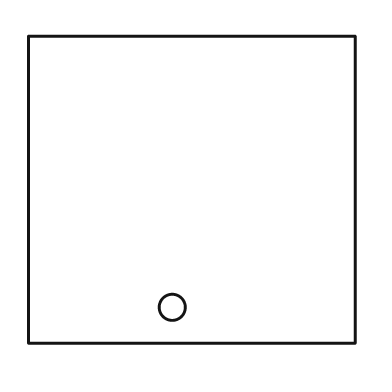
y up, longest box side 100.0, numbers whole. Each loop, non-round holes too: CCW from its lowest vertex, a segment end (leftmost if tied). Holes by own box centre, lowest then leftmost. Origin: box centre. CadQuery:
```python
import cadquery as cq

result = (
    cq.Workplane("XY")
    .moveTo(-50.0, -47.0)
    .lineTo(50.0, -47.0)
    .lineTo(50.0, 47.0)
    .lineTo(-50.0, 47.0)
    .close()
    .moveTo(-6.0, -36.0)
    .circle(4.0)
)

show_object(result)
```